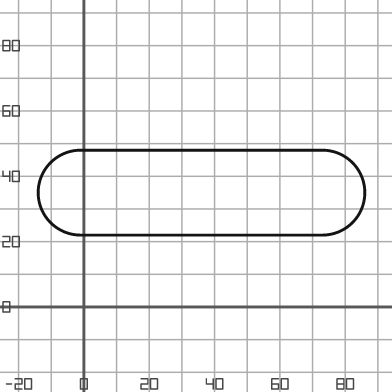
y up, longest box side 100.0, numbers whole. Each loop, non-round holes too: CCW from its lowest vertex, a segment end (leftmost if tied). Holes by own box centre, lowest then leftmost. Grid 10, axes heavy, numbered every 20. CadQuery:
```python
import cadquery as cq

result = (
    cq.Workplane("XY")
    .moveTo(-1.0, 22.0)
    .lineTo(73.0, 22.0)
    .threePointArc((86.0, 35.0), (73.0, 48.0))
    .lineTo(-1.0, 48.0)
    .threePointArc((-14.0, 35.0), (-1.0, 22.0))
    .close()
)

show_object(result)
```